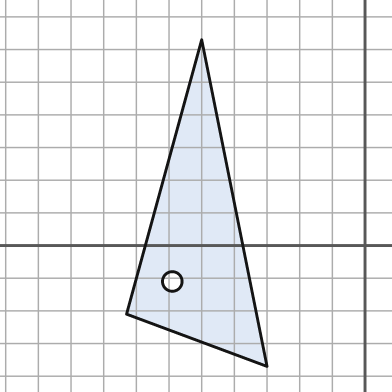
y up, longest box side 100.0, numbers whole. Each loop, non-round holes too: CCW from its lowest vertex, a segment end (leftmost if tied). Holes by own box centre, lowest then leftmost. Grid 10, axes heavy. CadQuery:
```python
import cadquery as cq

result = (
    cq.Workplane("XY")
    .moveTo(-30.0, -37.0)
    .lineTo(-50.0, 63.0)
    .lineTo(-73.0, -21.0)
    .close()
    .moveTo(-59.0, -11.0)
    .circle(3.0)
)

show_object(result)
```